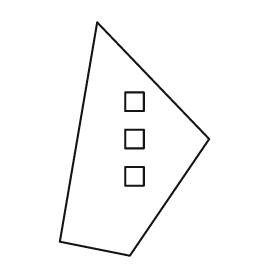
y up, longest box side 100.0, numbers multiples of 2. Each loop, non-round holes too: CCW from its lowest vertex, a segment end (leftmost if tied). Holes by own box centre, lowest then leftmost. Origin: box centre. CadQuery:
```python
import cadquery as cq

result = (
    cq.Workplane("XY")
    .moveTo(-2.0, -50.0)
    .lineTo(32.0, 0.0)
    .lineTo(-16.0, 50.0)
    .lineTo(-32.0, -44.0)
    .close()
    .moveTo(-4.0, -20.0)
    .lineTo(4.0, -20.0)
    .lineTo(4.0, -12.0)
    .lineTo(-4.0, -12.0)
    .close()
    .moveTo(-4.0, -4.0)
    .lineTo(4.0, -4.0)
    .lineTo(4.0, 4.0)
    .lineTo(-4.0, 4.0)
    .close()
    .moveTo(-4.0, 12.0)
    .lineTo(4.0, 12.0)
    .lineTo(4.0, 20.0)
    .lineTo(-4.0, 20.0)
    .close()
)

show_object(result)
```